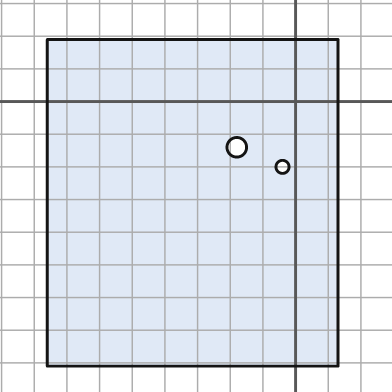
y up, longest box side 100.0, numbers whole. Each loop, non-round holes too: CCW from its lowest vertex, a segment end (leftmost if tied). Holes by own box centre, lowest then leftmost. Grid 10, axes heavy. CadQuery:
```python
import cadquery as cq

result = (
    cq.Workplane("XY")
    .moveTo(-76.0, -81.0)
    .lineTo(13.0, -81.0)
    .lineTo(13.0, 19.0)
    .lineTo(-76.0, 19.0)
    .close()
    .moveTo(-4.0, -20.0)
    .circle(2.0)
    .moveTo(-18.0, -14.0)
    .circle(3.0)
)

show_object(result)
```